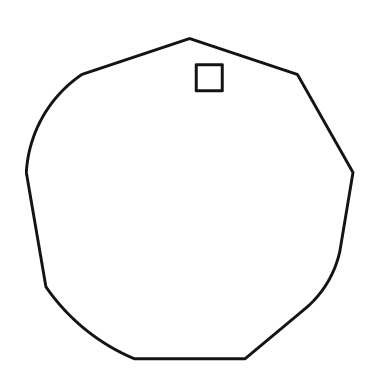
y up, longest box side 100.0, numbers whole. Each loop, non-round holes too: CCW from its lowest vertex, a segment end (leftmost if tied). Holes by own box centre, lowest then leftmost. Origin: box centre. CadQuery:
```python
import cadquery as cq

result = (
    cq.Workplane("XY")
    .moveTo(-17.0, -49.0)
    .lineTo(17.0, -49.0)
    .lineTo(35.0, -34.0)
    .threePointArc((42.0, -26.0), (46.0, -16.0))
    .lineTo(50.0, 8.0)
    .lineTo(33.0, 38.0)
    .lineTo(0.0, 49.0)
    .lineTo(-33.0, 38.0)
    .threePointArc((-45.0, 25.0), (-50.0, 8.0))
    .lineTo(-44.0, -27.0)
    .threePointArc((-32.0, -40.0), (-17.0, -49.0))
    .close()
    .moveTo(2.0, 33.0)
    .lineTo(10.0, 33.0)
    .lineTo(10.0, 41.0)
    .lineTo(2.0, 41.0)
    .close()
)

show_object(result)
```